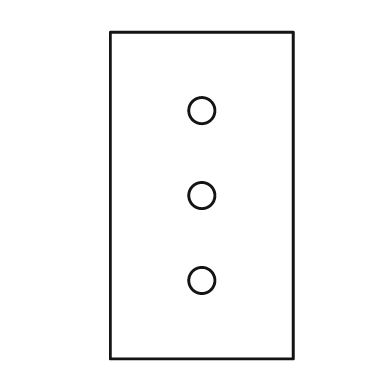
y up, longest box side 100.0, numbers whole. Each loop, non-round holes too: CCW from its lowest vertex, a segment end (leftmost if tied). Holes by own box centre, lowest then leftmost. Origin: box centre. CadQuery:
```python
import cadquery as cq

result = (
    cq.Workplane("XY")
    .moveTo(-28.0, -50.0)
    .lineTo(28.0, -50.0)
    .lineTo(28.0, 50.0)
    .lineTo(-28.0, 50.0)
    .close()
    .moveTo(0.0, -26.0)
    .circle(4.0)
    .moveTo(0.0, 0.0)
    .circle(4.0)
    .moveTo(0.0, 26.0)
    .circle(4.0)
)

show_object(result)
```